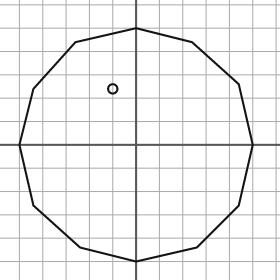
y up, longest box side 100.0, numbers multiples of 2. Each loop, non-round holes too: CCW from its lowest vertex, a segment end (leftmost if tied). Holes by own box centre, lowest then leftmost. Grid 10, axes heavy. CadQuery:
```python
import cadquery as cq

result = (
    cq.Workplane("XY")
    .moveTo(0.0, -50.0)
    .lineTo(26.0, -44.0)
    .lineTo(44.0, -26.0)
    .lineTo(50.0, 0.0)
    .lineTo(44.0, 26.0)
    .lineTo(24.0, 44.0)
    .lineTo(0.0, 50.0)
    .lineTo(-26.0, 44.0)
    .lineTo(-44.0, 24.0)
    .lineTo(-50.0, 0.0)
    .lineTo(-44.0, -26.0)
    .lineTo(-24.0, -44.0)
    .close()
    .moveTo(-10.0, 24.0)
    .circle(2.0)
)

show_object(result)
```